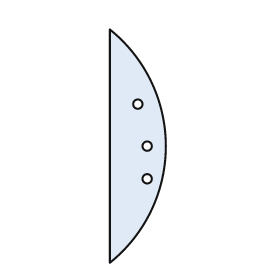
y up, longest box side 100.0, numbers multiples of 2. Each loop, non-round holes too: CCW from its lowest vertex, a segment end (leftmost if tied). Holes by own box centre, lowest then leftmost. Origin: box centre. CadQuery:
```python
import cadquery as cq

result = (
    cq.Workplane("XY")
    .moveTo(-12.0, -50.0)
    .threePointArc((12.0, 0.0), (-12.0, 50.0))
    .close()
    .moveTo(4.0, -14.0)
    .circle(2.0)
    .moveTo(4.0, 0.0)
    .circle(2.0)
    .moveTo(0.0, 18.0)
    .circle(2.0)
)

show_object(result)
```